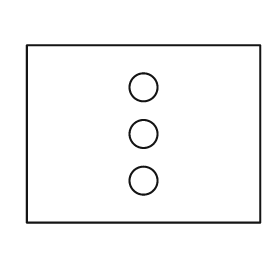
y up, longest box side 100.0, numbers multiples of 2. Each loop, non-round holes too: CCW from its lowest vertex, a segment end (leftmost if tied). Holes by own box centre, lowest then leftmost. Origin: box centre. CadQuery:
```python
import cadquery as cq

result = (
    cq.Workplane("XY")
    .moveTo(-50.0, -38.0)
    .lineTo(50.0, -38.0)
    .lineTo(50.0, 38.0)
    .lineTo(-50.0, 38.0)
    .close()
    .moveTo(0.0, -20.0)
    .circle(6.0)
    .moveTo(0.0, 0.0)
    .circle(6.0)
    .moveTo(0.0, 20.0)
    .circle(6.0)
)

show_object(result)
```